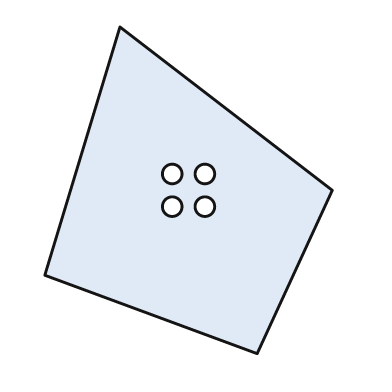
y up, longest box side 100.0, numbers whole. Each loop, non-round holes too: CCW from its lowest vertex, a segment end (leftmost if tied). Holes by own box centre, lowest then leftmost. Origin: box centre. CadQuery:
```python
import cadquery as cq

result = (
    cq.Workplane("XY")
    .moveTo(21.0, -50.0)
    .lineTo(44.0, 0.0)
    .lineTo(-21.0, 50.0)
    .lineTo(-44.0, -26.0)
    .close()
    .moveTo(-5.0, -5.0)
    .circle(3.0)
    .moveTo(5.0, -5.0)
    .circle(3.0)
    .moveTo(-5.0, 5.0)
    .circle(3.0)
    .moveTo(5.0, 5.0)
    .circle(3.0)
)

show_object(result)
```